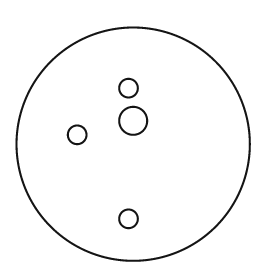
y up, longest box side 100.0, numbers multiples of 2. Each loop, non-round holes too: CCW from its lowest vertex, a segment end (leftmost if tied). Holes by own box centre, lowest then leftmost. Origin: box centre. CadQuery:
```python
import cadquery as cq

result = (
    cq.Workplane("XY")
    .moveTo(0.0, 0.0)
    .circle(50.0)
    .moveTo(-2.0, -32.0)
    .circle(4.0)
    .moveTo(-24.0, 4.0)
    .circle(4.0)
    .moveTo(0.0, 10.0)
    .circle(6.0)
    .moveTo(-2.0, 24.0)
    .circle(4.0)
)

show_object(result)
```